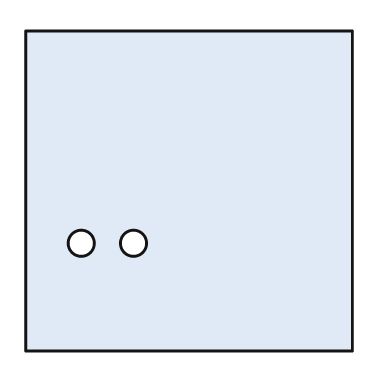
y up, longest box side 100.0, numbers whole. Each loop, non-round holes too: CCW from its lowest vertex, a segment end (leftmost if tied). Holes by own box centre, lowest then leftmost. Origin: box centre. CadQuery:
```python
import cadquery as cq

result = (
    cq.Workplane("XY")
    .moveTo(-50.0, -49.0)
    .lineTo(50.0, -49.0)
    .lineTo(50.0, 49.0)
    .lineTo(-50.0, 49.0)
    .close()
    .moveTo(-33.0, -16.0)
    .circle(4.0)
    .moveTo(-17.0, -16.0)
    .circle(4.0)
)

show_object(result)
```